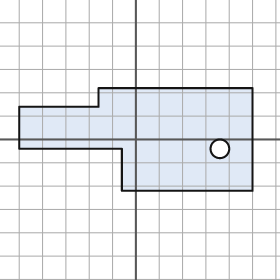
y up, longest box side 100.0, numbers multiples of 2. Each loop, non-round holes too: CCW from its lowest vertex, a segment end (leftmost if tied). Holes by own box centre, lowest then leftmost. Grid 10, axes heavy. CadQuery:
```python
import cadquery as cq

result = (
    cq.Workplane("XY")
    .moveTo(-6.0, -22.0)
    .lineTo(50.0, -22.0)
    .lineTo(50.0, 22.0)
    .lineTo(-16.0, 22.0)
    .lineTo(-16.0, 14.0)
    .lineTo(-50.0, 14.0)
    .lineTo(-50.0, -4.0)
    .lineTo(-6.0, -4.0)
    .close()
    .moveTo(36.0, -4.0)
    .circle(4.0)
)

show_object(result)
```